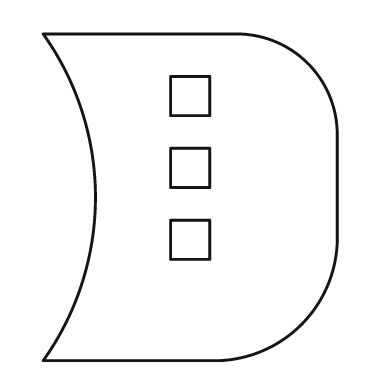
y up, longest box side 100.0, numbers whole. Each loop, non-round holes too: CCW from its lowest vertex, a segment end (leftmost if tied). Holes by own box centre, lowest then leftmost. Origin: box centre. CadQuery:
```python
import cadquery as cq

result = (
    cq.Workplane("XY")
    .moveTo(-45.0, -50.0)
    .lineTo(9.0, -50.0)
    .threePointArc((34.0, -39.0), (45.0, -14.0))
    .lineTo(45.0, 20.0)
    .threePointArc((36.0, 41.0), (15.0, 50.0))
    .lineTo(-45.0, 50.0)
    .threePointArc((-29.0, 0.0), (-45.0, -50.0))
    .close()
    .moveTo(-6.0, -19.0)
    .lineTo(6.0, -19.0)
    .lineTo(6.0, -7.0)
    .lineTo(-6.0, -7.0)
    .close()
    .moveTo(-6.0, 3.0)
    .lineTo(6.0, 3.0)
    .lineTo(6.0, 15.0)
    .lineTo(-6.0, 15.0)
    .close()
    .moveTo(-6.0, 25.0)
    .lineTo(6.0, 25.0)
    .lineTo(6.0, 37.0)
    .lineTo(-6.0, 37.0)
    .close()
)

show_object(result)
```